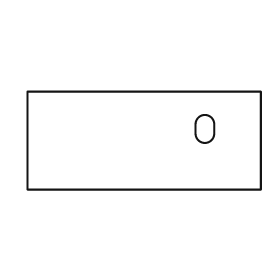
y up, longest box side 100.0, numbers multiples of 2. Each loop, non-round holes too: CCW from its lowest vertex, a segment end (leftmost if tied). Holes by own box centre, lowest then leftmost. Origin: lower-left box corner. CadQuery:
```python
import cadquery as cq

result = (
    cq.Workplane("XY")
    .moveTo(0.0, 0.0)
    .lineTo(100.0, 0.0)
    .lineTo(100.0, 42.0)
    .lineTo(0.0, 42.0)
    .close()
    .moveTo(72.0, 24.0)
    .threePointArc((76.0, 20.0), (80.0, 24.0))
    .lineTo(80.0, 28.0)
    .threePointArc((76.0, 32.0), (72.0, 28.0))
    .close()
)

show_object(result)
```